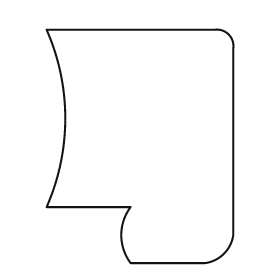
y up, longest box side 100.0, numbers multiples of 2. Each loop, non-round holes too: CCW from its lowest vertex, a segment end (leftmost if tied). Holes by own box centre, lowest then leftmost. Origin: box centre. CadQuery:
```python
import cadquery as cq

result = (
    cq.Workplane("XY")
    .moveTo(-4.0, -50.0)
    .lineTo(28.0, -50.0)
    .threePointArc((36.0, -46.0), (40.0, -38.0))
    .lineTo(40.0, 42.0)
    .threePointArc((38.0, 48.0), (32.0, 50.0))
    .lineTo(-40.0, 50.0)
    .threePointArc((-32.0, 12.0), (-40.0, -26.0))
    .lineTo(-4.0, -26.0)
    .threePointArc((-8.0, -38.0), (-4.0, -50.0))
    .close()
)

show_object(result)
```